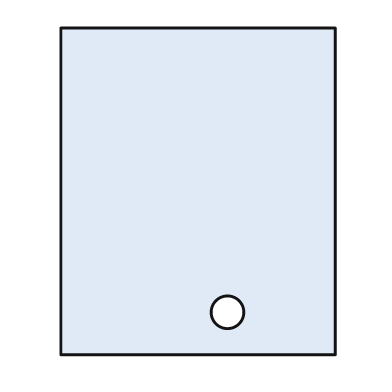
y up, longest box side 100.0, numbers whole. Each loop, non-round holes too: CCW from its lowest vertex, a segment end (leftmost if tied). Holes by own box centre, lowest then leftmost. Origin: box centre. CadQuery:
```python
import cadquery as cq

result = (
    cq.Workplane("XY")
    .moveTo(-42.0, -50.0)
    .lineTo(42.0, -50.0)
    .lineTo(42.0, 50.0)
    .lineTo(-42.0, 50.0)
    .close()
    .moveTo(9.0, -37.0)
    .circle(5.0)
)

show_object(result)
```